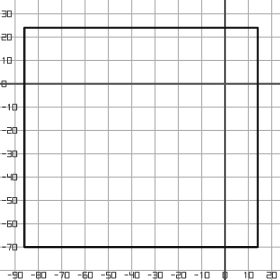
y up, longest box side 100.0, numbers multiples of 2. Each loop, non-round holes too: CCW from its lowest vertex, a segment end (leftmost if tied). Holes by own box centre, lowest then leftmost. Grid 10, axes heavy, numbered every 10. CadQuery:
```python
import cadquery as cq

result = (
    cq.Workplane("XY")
    .moveTo(-86.0, -70.0)
    .lineTo(14.0, -70.0)
    .lineTo(14.0, 24.0)
    .lineTo(-86.0, 24.0)
    .close()
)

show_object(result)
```